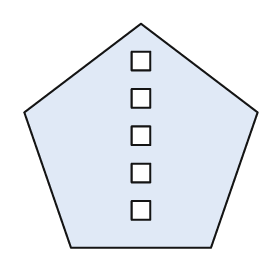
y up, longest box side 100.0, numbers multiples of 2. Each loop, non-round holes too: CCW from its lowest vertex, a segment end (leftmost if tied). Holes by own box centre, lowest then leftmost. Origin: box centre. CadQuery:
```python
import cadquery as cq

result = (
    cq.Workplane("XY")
    .moveTo(-30.0, -48.0)
    .lineTo(30.0, -48.0)
    .lineTo(50.0, 10.0)
    .lineTo(0.0, 48.0)
    .lineTo(-50.0, 10.0)
    .close()
    .moveTo(-4.0, -36.0)
    .lineTo(4.0, -36.0)
    .lineTo(4.0, -28.0)
    .lineTo(-4.0, -28.0)
    .close()
    .moveTo(-4.0, -20.0)
    .lineTo(4.0, -20.0)
    .lineTo(4.0, -12.0)
    .lineTo(-4.0, -12.0)
    .close()
    .moveTo(-4.0, -4.0)
    .lineTo(4.0, -4.0)
    .lineTo(4.0, 4.0)
    .lineTo(-4.0, 4.0)
    .close()
    .moveTo(-4.0, 12.0)
    .lineTo(4.0, 12.0)
    .lineTo(4.0, 20.0)
    .lineTo(-4.0, 20.0)
    .close()
    .moveTo(-4.0, 28.0)
    .lineTo(4.0, 28.0)
    .lineTo(4.0, 36.0)
    .lineTo(-4.0, 36.0)
    .close()
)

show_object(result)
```